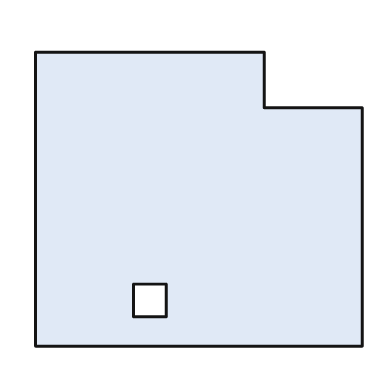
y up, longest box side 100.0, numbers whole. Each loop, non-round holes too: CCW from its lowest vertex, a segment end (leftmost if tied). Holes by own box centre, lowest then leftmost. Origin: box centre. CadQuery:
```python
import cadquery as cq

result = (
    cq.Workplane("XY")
    .moveTo(-50.0, -45.0)
    .lineTo(50.0, -45.0)
    .lineTo(50.0, 28.0)
    .lineTo(20.0, 28.0)
    .lineTo(20.0, 45.0)
    .lineTo(-50.0, 45.0)
    .close()
    .moveTo(-20.0, -36.0)
    .lineTo(-10.0, -36.0)
    .lineTo(-10.0, -26.0)
    .lineTo(-20.0, -26.0)
    .close()
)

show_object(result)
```